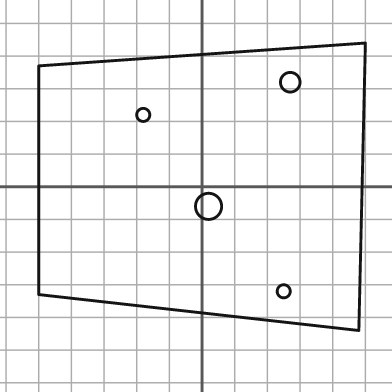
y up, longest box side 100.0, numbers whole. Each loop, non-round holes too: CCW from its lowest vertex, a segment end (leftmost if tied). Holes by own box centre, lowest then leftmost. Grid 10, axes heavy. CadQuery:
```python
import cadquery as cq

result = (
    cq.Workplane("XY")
    .moveTo(48.0, -44.0)
    .lineTo(50.0, 44.0)
    .lineTo(-50.0, 37.0)
    .lineTo(-50.0, -33.0)
    .close()
    .moveTo(25.0, -32.0)
    .circle(2.0)
    .moveTo(2.0, -6.0)
    .circle(4.0)
    .moveTo(-18.0, 22.0)
    .circle(2.0)
    .moveTo(27.0, 32.0)
    .circle(3.0)
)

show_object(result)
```